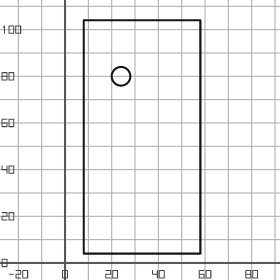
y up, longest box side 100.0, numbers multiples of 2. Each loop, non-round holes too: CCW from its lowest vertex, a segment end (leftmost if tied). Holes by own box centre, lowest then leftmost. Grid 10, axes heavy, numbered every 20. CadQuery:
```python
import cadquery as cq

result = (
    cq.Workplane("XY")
    .moveTo(8.0, 4.0)
    .lineTo(58.0, 4.0)
    .lineTo(58.0, 104.0)
    .lineTo(8.0, 104.0)
    .close()
    .moveTo(24.0, 80.0)
    .circle(4.0)
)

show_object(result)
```